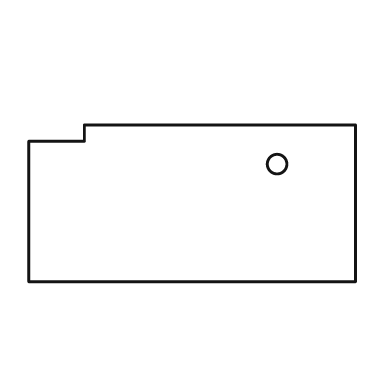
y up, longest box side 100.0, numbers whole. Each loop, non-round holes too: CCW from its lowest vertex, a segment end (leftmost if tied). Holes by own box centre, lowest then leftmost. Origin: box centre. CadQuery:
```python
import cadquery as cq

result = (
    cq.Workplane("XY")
    .moveTo(-50.0, -24.0)
    .lineTo(50.0, -24.0)
    .lineTo(50.0, 24.0)
    .lineTo(-33.0, 24.0)
    .lineTo(-33.0, 19.0)
    .lineTo(-50.0, 19.0)
    .close()
    .moveTo(26.0, 12.0)
    .circle(3.0)
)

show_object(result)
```